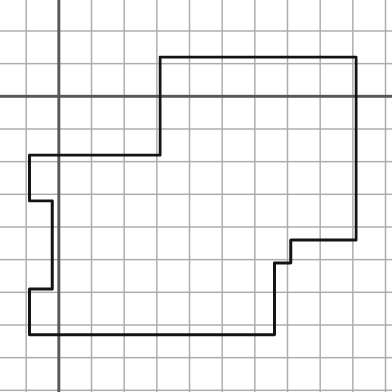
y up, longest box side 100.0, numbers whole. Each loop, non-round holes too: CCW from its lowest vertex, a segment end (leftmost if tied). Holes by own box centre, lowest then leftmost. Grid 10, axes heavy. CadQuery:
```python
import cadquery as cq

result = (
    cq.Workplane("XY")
    .moveTo(-9.0, -73.0)
    .lineTo(66.0, -73.0)
    .lineTo(66.0, -51.0)
    .lineTo(71.0, -51.0)
    .lineTo(71.0, -44.0)
    .lineTo(91.0, -44.0)
    .lineTo(91.0, 12.0)
    .lineTo(31.0, 12.0)
    .lineTo(31.0, -18.0)
    .lineTo(-9.0, -18.0)
    .lineTo(-9.0, -32.0)
    .lineTo(-2.0, -32.0)
    .lineTo(-2.0, -59.0)
    .lineTo(-9.0, -59.0)
    .close()
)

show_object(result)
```